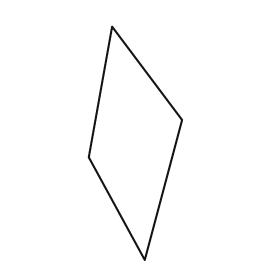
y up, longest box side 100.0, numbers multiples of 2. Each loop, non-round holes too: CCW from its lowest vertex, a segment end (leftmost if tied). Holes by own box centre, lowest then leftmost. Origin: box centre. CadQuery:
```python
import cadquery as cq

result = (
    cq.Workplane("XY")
    .moveTo(4.0, -50.0)
    .lineTo(20.0, 10.0)
    .lineTo(-10.0, 50.0)
    .lineTo(-20.0, -6.0)
    .close()
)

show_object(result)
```